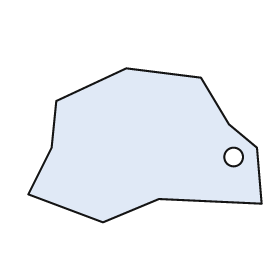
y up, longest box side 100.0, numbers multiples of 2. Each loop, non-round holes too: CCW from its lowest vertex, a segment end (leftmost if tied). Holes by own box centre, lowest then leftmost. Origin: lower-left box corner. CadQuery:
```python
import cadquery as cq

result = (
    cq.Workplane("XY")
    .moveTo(32.0, 0.0)
    .lineTo(56.0, 10.0)
    .lineTo(100.0, 8.0)
    .lineTo(98.0, 32.0)
    .lineTo(86.0, 42.0)
    .lineTo(74.0, 62.0)
    .lineTo(42.0, 66.0)
    .lineTo(12.0, 52.0)
    .lineTo(10.0, 32.0)
    .lineTo(0.0, 12.0)
    .close()
    .moveTo(88.0, 28.0)
    .circle(4.0)
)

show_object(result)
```